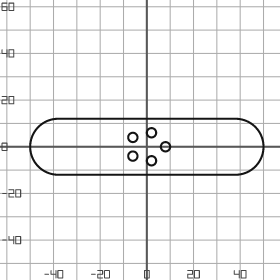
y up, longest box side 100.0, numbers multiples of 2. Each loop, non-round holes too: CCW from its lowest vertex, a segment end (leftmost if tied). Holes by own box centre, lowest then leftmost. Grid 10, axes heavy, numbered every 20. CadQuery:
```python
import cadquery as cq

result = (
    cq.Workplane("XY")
    .moveTo(-38.0, -12.0)
    .lineTo(38.0, -12.0)
    .threePointArc((50.0, 0.0), (38.0, 12.0))
    .lineTo(-38.0, 12.0)
    .threePointArc((-50.0, 0.0), (-38.0, -12.0))
    .close()
    .moveTo(2.0, -6.0)
    .circle(2.0)
    .moveTo(-6.0, -4.0)
    .circle(2.0)
    .moveTo(8.0, 0.0)
    .circle(2.0)
    .moveTo(-6.0, 4.0)
    .circle(2.0)
    .moveTo(2.0, 6.0)
    .circle(2.0)
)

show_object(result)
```